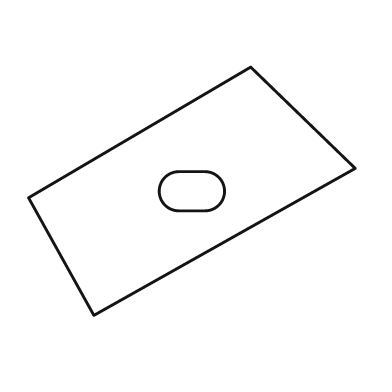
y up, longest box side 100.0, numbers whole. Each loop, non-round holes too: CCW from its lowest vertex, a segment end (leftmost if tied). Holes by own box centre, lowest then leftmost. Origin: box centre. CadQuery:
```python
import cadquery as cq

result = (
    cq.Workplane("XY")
    .moveTo(-30.0, -38.0)
    .lineTo(50.0, 7.0)
    .lineTo(18.0, 38.0)
    .lineTo(-50.0, -2.0)
    .close()
    .moveTo(-4.0, -6.0)
    .lineTo(4.0, -6.0)
    .threePointArc((10.0, 0.0), (4.0, 6.0))
    .lineTo(-4.0, 6.0)
    .threePointArc((-10.0, 0.0), (-4.0, -6.0))
    .close()
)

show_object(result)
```